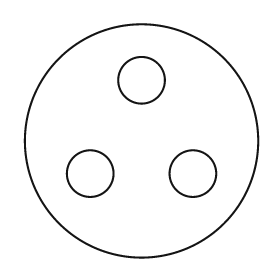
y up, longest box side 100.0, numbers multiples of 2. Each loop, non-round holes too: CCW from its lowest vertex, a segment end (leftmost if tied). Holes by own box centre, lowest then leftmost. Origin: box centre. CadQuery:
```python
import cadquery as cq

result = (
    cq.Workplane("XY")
    .moveTo(0.0, 0.0)
    .circle(50.0)
    .moveTo(-22.0, -14.0)
    .circle(10.0)
    .moveTo(22.0, -14.0)
    .circle(10.0)
    .moveTo(0.0, 26.0)
    .circle(10.0)
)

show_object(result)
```